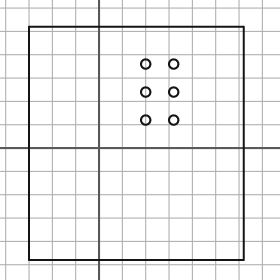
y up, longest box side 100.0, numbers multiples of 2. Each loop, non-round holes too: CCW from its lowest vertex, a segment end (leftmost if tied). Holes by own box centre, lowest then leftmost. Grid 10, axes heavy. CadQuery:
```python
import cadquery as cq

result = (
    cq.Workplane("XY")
    .moveTo(-30.0, -48.0)
    .lineTo(62.0, -48.0)
    .lineTo(62.0, 52.0)
    .lineTo(-30.0, 52.0)
    .close()
    .moveTo(20.0, 12.0)
    .circle(2.0)
    .moveTo(32.0, 12.0)
    .circle(2.0)
    .moveTo(20.0, 24.0)
    .circle(2.0)
    .moveTo(32.0, 24.0)
    .circle(2.0)
    .moveTo(20.0, 36.0)
    .circle(2.0)
    .moveTo(32.0, 36.0)
    .circle(2.0)
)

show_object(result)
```